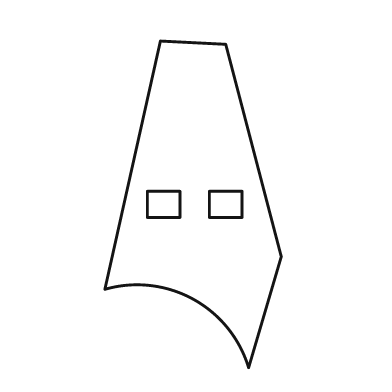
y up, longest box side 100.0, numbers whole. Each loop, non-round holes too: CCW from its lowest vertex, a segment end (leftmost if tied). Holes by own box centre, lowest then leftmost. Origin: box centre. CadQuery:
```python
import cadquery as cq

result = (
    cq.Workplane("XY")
    .moveTo(17.0, -50.0)
    .lineTo(27.0, -16.0)
    .lineTo(10.0, 49.0)
    .lineTo(-10.0, 50.0)
    .lineTo(-27.0, -26.0)
    .threePointArc((0.0, -29.0), (17.0, -50.0))
    .close()
    .moveTo(-14.0, -4.0)
    .lineTo(-4.0, -4.0)
    .lineTo(-4.0, 4.0)
    .lineTo(-14.0, 4.0)
    .close()
    .moveTo(5.0, -4.0)
    .lineTo(15.0, -4.0)
    .lineTo(15.0, 4.0)
    .lineTo(5.0, 4.0)
    .close()
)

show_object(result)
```